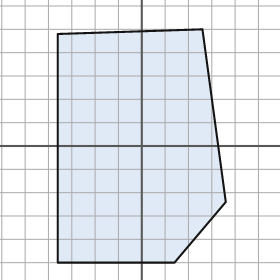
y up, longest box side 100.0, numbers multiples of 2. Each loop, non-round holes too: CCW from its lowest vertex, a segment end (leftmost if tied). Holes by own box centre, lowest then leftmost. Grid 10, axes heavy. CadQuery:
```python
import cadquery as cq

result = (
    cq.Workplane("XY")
    .moveTo(-36.0, -50.0)
    .lineTo(14.0, -50.0)
    .lineTo(36.0, -24.0)
    .lineTo(26.0, 50.0)
    .lineTo(-36.0, 48.0)
    .close()
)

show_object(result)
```